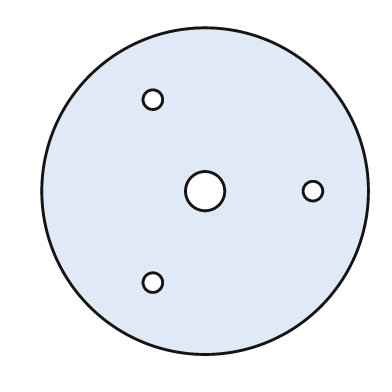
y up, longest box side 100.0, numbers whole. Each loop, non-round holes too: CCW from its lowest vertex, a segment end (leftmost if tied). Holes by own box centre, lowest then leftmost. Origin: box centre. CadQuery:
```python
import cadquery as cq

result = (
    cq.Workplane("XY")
    .moveTo(0.0, 0.0)
    .circle(50.0)
    .moveTo(-16.0, -28.0)
    .circle(3.0)
    .moveTo(0.0, 0.0)
    .circle(6.0)
    .moveTo(33.0, 0.0)
    .circle(3.0)
    .moveTo(-16.0, 28.0)
    .circle(3.0)
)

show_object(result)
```